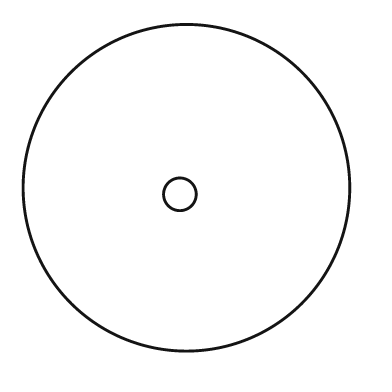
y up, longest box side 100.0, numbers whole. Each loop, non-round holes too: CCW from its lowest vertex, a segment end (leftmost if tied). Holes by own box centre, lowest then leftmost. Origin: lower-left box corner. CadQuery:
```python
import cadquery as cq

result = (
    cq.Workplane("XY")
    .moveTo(50.0, 50.0)
    .circle(50.0)
    .moveTo(48.0, 48.0)
    .circle(5.0)
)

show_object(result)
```